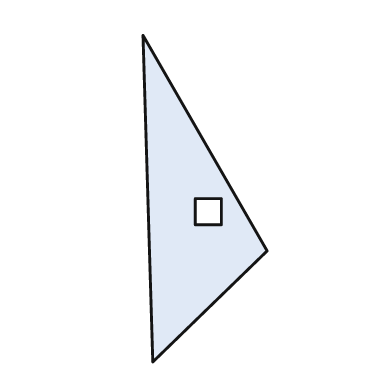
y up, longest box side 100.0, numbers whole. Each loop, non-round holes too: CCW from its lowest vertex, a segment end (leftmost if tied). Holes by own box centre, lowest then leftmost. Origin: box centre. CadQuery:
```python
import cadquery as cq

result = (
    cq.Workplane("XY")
    .moveTo(-16.0, -50.0)
    .lineTo(19.0, -16.0)
    .lineTo(-19.0, 50.0)
    .close()
    .moveTo(-3.0, -8.0)
    .lineTo(5.0, -8.0)
    .lineTo(5.0, 0.0)
    .lineTo(-3.0, 0.0)
    .close()
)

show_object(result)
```